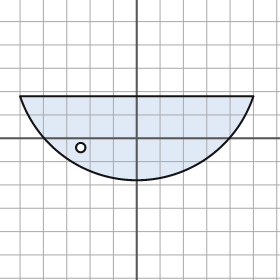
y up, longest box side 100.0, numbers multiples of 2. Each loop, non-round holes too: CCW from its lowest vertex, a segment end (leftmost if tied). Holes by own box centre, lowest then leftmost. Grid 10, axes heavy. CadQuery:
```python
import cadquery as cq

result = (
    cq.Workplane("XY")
    .moveTo(-50.0, 18.0)
    .threePointArc((0.0, -18.0), (50.0, 18.0))
    .close()
    .moveTo(-24.0, -4.0)
    .circle(2.0)
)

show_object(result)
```